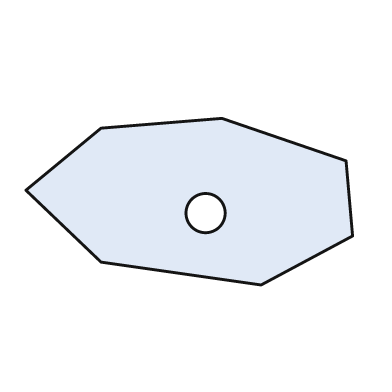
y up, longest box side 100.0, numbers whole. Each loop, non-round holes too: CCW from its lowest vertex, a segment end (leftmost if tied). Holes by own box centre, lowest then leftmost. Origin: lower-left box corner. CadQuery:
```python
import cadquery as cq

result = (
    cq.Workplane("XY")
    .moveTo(72.0, 0.0)
    .lineTo(100.0, 15.0)
    .lineTo(98.0, 38.0)
    .lineTo(60.0, 51.0)
    .lineTo(23.0, 48.0)
    .lineTo(0.0, 29.0)
    .lineTo(23.0, 7.0)
    .close()
    .moveTo(55.0, 22.0)
    .circle(6.0)
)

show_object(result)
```